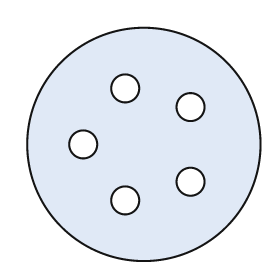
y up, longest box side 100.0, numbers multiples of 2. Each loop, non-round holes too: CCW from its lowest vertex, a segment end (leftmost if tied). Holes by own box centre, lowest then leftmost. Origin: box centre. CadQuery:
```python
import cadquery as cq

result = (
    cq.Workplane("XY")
    .moveTo(0.0, 0.0)
    .circle(50.0)
    .moveTo(-8.0, -24.0)
    .circle(6.0)
    .moveTo(20.0, -16.0)
    .circle(6.0)
    .moveTo(-26.0, 0.0)
    .circle(6.0)
    .moveTo(20.0, 16.0)
    .circle(6.0)
    .moveTo(-8.0, 24.0)
    .circle(6.0)
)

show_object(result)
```